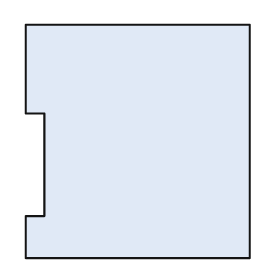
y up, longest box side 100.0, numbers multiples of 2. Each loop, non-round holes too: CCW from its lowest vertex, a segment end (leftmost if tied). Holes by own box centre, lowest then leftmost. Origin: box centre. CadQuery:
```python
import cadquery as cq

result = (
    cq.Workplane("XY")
    .moveTo(-48.0, -50.0)
    .lineTo(48.0, -50.0)
    .lineTo(48.0, 50.0)
    .lineTo(-48.0, 50.0)
    .lineTo(-48.0, 12.0)
    .lineTo(-40.0, 12.0)
    .lineTo(-40.0, -32.0)
    .lineTo(-48.0, -32.0)
    .close()
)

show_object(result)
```